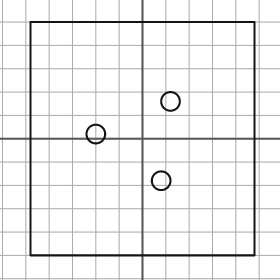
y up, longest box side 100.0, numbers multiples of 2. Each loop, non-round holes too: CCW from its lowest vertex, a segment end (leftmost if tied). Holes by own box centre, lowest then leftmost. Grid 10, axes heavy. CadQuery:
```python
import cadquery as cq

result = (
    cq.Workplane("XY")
    .moveTo(-48.0, -50.0)
    .lineTo(48.0, -50.0)
    .lineTo(48.0, 50.0)
    .lineTo(-48.0, 50.0)
    .close()
    .moveTo(8.0, -18.0)
    .circle(4.0)
    .moveTo(-20.0, 2.0)
    .circle(4.0)
    .moveTo(12.0, 16.0)
    .circle(4.0)
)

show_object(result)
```